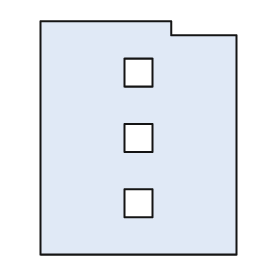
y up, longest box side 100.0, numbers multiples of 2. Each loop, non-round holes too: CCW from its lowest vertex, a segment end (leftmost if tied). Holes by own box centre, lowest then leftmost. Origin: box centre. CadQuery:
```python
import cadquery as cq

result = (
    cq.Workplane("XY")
    .moveTo(-42.0, -50.0)
    .lineTo(42.0, -50.0)
    .lineTo(42.0, 44.0)
    .lineTo(14.0, 44.0)
    .lineTo(14.0, 50.0)
    .lineTo(-42.0, 50.0)
    .close()
    .moveTo(-6.0, -34.0)
    .lineTo(6.0, -34.0)
    .lineTo(6.0, -22.0)
    .lineTo(-6.0, -22.0)
    .close()
    .moveTo(-6.0, -6.0)
    .lineTo(6.0, -6.0)
    .lineTo(6.0, 6.0)
    .lineTo(-6.0, 6.0)
    .close()
    .moveTo(-6.0, 22.0)
    .lineTo(6.0, 22.0)
    .lineTo(6.0, 34.0)
    .lineTo(-6.0, 34.0)
    .close()
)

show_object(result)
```